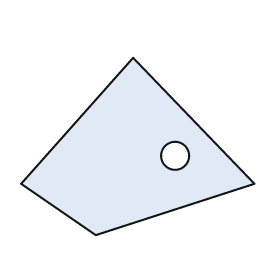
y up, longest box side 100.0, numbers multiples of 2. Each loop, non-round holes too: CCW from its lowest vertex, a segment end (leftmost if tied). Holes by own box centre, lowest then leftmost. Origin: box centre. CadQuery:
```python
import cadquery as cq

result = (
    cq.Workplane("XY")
    .moveTo(-18.0, -38.0)
    .lineTo(50.0, -16.0)
    .lineTo(-2.0, 38.0)
    .lineTo(-50.0, -16.0)
    .close()
    .moveTo(16.0, -4.0)
    .circle(6.0)
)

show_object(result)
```